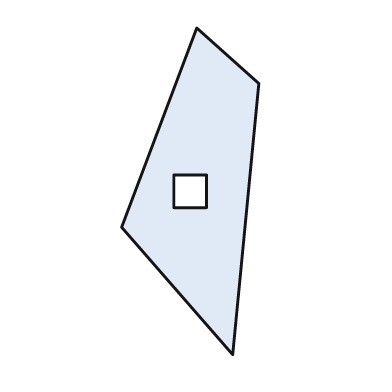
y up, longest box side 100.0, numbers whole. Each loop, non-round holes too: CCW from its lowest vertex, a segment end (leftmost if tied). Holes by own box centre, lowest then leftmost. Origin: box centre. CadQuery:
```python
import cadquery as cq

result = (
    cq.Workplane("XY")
    .moveTo(13.0, -50.0)
    .lineTo(21.0, 33.0)
    .lineTo(2.0, 50.0)
    .lineTo(-21.0, -11.0)
    .close()
    .moveTo(-5.0, -5.0)
    .lineTo(5.0, -5.0)
    .lineTo(5.0, 5.0)
    .lineTo(-5.0, 5.0)
    .close()
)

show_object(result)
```